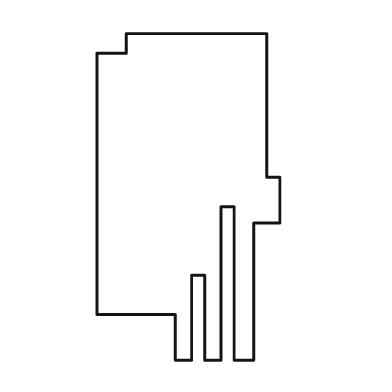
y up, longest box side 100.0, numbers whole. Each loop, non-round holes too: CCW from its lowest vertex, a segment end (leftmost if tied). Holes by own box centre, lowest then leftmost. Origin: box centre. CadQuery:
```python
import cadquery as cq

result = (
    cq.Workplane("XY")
    .moveTo(-4.0, -50.0)
    .lineTo(1.0, -50.0)
    .lineTo(1.0, -24.0)
    .lineTo(5.0, -24.0)
    .lineTo(5.0, -50.0)
    .lineTo(10.0, -50.0)
    .lineTo(10.0, -3.0)
    .lineTo(14.0, -3.0)
    .lineTo(14.0, -50.0)
    .lineTo(20.0, -50.0)
    .lineTo(20.0, -8.0)
    .lineTo(28.0, -8.0)
    .lineTo(28.0, 6.0)
    .lineTo(24.0, 6.0)
    .lineTo(24.0, 50.0)
    .lineTo(-19.0, 50.0)
    .lineTo(-19.0, 44.0)
    .lineTo(-28.0, 44.0)
    .lineTo(-28.0, -36.0)
    .lineTo(-4.0, -36.0)
    .close()
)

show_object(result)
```